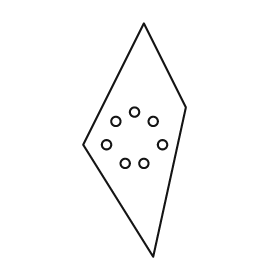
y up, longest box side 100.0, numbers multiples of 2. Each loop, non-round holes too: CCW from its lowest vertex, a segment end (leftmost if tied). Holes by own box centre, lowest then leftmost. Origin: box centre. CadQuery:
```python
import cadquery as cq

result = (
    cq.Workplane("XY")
    .moveTo(8.0, -50.0)
    .lineTo(22.0, 14.0)
    .lineTo(4.0, 50.0)
    .lineTo(-22.0, -2.0)
    .close()
    .moveTo(-4.0, -10.0)
    .circle(2.0)
    .moveTo(4.0, -10.0)
    .circle(2.0)
    .moveTo(-12.0, -2.0)
    .circle(2.0)
    .moveTo(12.0, -2.0)
    .circle(2.0)
    .moveTo(-8.0, 8.0)
    .circle(2.0)
    .moveTo(8.0, 8.0)
    .circle(2.0)
    .moveTo(0.0, 12.0)
    .circle(2.0)
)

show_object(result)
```